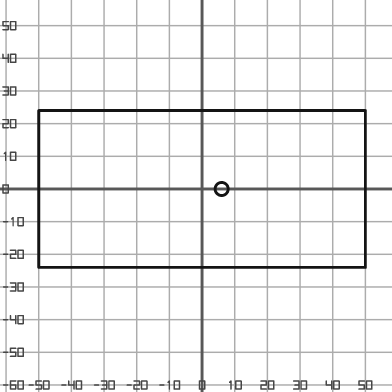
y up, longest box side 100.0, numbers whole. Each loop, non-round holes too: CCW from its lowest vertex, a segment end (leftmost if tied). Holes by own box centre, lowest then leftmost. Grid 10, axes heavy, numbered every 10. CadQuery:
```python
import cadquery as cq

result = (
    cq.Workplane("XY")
    .moveTo(-50.0, -24.0)
    .lineTo(50.0, -24.0)
    .lineTo(50.0, 24.0)
    .lineTo(-50.0, 24.0)
    .close()
    .moveTo(6.0, 0.0)
    .circle(2.0)
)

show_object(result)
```